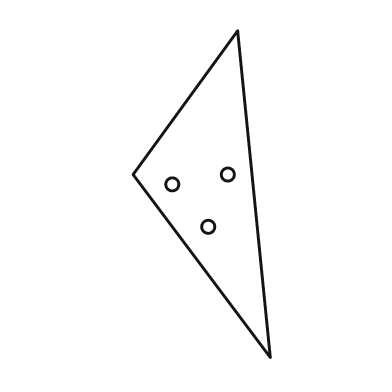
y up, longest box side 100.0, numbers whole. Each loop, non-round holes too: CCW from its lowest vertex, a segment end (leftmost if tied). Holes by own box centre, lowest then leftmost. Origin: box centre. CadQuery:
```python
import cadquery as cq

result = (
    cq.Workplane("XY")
    .moveTo(21.0, -50.0)
    .lineTo(11.0, 50.0)
    .lineTo(-21.0, 6.0)
    .close()
    .moveTo(2.0, -10.0)
    .circle(2.0)
    .moveTo(-9.0, 3.0)
    .circle(2.0)
    .moveTo(8.0, 6.0)
    .circle(2.0)
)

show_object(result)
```